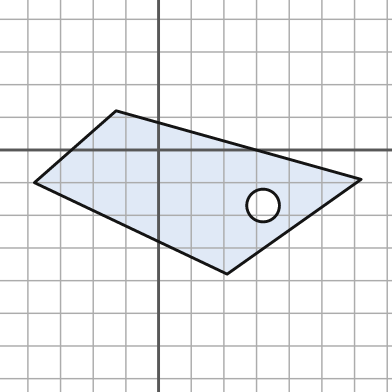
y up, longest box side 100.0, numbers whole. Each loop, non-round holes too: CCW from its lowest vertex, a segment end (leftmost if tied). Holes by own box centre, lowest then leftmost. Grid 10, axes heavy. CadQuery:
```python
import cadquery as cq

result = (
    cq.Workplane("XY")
    .moveTo(21.0, -38.0)
    .lineTo(62.0, -9.0)
    .lineTo(-13.0, 12.0)
    .lineTo(-38.0, -10.0)
    .close()
    .moveTo(32.0, -17.0)
    .circle(5.0)
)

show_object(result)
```